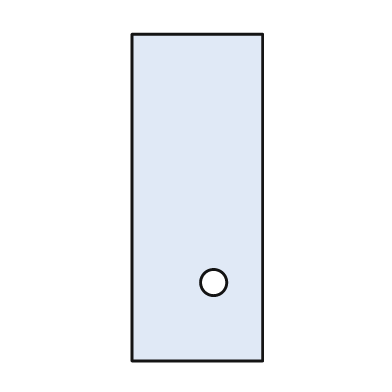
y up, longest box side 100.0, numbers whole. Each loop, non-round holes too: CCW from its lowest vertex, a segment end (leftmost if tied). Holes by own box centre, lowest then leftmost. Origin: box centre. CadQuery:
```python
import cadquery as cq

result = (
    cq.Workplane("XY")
    .moveTo(-20.0, -50.0)
    .lineTo(20.0, -50.0)
    .lineTo(20.0, 50.0)
    .lineTo(-20.0, 50.0)
    .close()
    .moveTo(5.0, -26.0)
    .circle(4.0)
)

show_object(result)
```